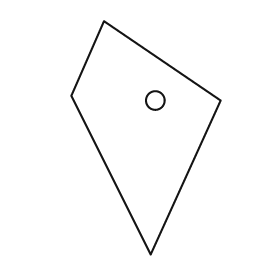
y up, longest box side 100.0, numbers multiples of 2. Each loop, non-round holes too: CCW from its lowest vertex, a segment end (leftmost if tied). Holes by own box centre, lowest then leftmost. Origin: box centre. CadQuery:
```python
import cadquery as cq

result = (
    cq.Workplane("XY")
    .moveTo(2.0, -50.0)
    .lineTo(32.0, 16.0)
    .lineTo(-18.0, 50.0)
    .lineTo(-32.0, 18.0)
    .close()
    .moveTo(4.0, 16.0)
    .circle(4.0)
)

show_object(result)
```